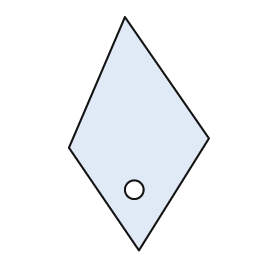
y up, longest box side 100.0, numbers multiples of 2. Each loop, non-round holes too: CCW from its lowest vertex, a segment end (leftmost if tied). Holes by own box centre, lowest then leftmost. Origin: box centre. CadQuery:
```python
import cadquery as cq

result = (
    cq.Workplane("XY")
    .moveTo(0.0, -50.0)
    .lineTo(30.0, -2.0)
    .lineTo(-6.0, 50.0)
    .lineTo(-30.0, -6.0)
    .close()
    .moveTo(-2.0, -24.0)
    .circle(4.0)
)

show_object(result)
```